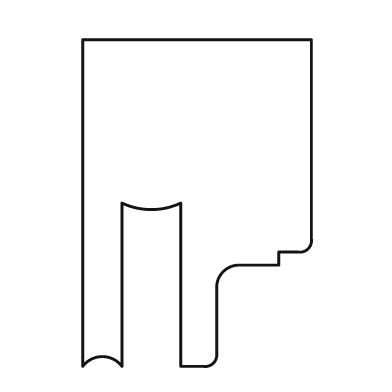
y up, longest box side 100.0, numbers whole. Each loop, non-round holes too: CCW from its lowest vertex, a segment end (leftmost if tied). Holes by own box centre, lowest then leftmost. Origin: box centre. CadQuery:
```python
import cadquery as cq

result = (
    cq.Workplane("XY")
    .moveTo(-35.0, -50.0)
    .threePointArc((-29.0, -47.0), (-23.0, -50.0))
    .lineTo(-23.0, 0.0)
    .threePointArc((-14.0, -2.0), (-5.0, 0.0))
    .lineTo(-5.0, -50.0)
    .lineTo(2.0, -50.0)
    .threePointArc((5.0, -49.0), (6.0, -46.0))
    .lineTo(6.0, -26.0)
    .threePointArc((8.0, -21.0), (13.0, -19.0))
    .lineTo(25.0, -19.0)
    .lineTo(25.0, -15.0)
    .lineTo(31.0, -15.0)
    .threePointArc((34.0, -14.0), (35.0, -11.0))
    .lineTo(35.0, 50.0)
    .lineTo(-35.0, 50.0)
    .close()
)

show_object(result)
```